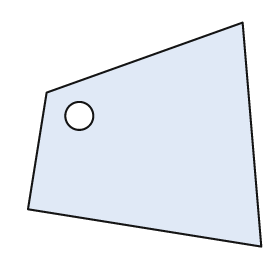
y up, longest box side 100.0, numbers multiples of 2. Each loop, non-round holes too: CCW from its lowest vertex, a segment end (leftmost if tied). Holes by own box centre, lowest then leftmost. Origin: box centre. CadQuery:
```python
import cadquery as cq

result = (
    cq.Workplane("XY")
    .moveTo(50.0, -48.0)
    .lineTo(42.0, 48.0)
    .lineTo(-42.0, 18.0)
    .lineTo(-50.0, -32.0)
    .close()
    .moveTo(-28.0, 8.0)
    .circle(6.0)
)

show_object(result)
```